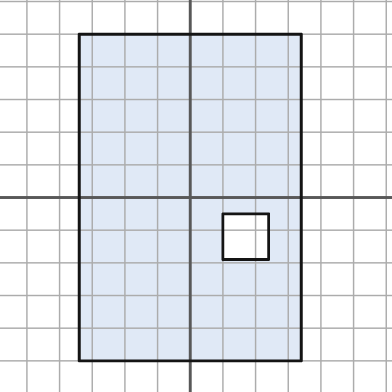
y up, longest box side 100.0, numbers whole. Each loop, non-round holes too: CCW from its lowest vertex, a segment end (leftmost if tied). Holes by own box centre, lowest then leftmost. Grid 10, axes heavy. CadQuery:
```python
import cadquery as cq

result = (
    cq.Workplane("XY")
    .moveTo(-34.0, -50.0)
    .lineTo(34.0, -50.0)
    .lineTo(34.0, 50.0)
    .lineTo(-34.0, 50.0)
    .close()
    .moveTo(10.0, -19.0)
    .lineTo(24.0, -19.0)
    .lineTo(24.0, -5.0)
    .lineTo(10.0, -5.0)
    .close()
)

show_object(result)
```